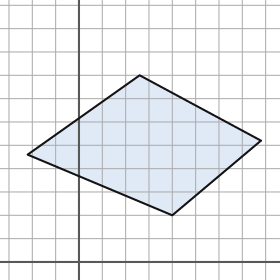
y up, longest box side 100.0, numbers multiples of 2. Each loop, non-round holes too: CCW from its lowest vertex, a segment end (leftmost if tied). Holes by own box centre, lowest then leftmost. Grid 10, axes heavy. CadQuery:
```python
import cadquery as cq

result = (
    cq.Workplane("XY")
    .moveTo(40.0, 20.0)
    .lineTo(78.0, 52.0)
    .lineTo(26.0, 80.0)
    .lineTo(-22.0, 46.0)
    .close()
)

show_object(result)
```